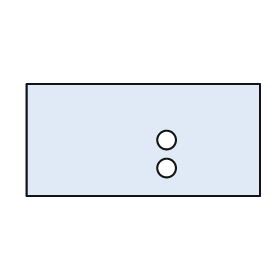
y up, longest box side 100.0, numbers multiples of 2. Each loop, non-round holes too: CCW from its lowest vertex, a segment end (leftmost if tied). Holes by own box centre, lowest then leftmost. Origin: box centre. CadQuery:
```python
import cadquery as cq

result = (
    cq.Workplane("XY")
    .moveTo(-50.0, -24.0)
    .lineTo(50.0, -24.0)
    .lineTo(50.0, 24.0)
    .lineTo(-50.0, 24.0)
    .close()
    .moveTo(10.0, -12.0)
    .circle(4.0)
    .moveTo(10.0, 0.0)
    .circle(4.0)
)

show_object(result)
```